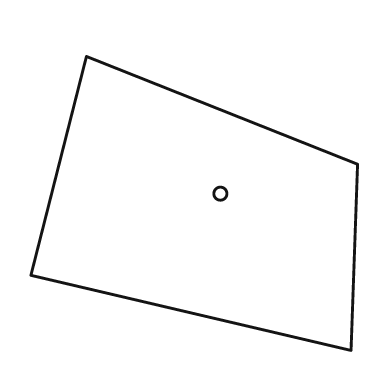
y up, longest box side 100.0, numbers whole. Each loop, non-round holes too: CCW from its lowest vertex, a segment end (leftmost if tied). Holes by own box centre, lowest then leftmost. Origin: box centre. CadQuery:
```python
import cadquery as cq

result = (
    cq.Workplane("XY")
    .moveTo(48.0, -45.0)
    .lineTo(50.0, 12.0)
    .lineTo(-33.0, 45.0)
    .lineTo(-50.0, -22.0)
    .close()
    .moveTo(8.0, 3.0)
    .circle(2.0)
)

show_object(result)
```